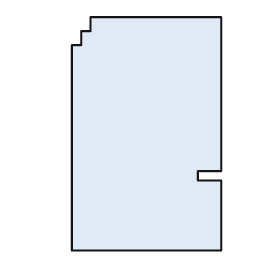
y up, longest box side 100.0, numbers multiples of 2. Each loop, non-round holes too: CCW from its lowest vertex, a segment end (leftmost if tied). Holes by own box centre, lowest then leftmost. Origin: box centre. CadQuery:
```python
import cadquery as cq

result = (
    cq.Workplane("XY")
    .moveTo(-32.0, -50.0)
    .lineTo(32.0, -50.0)
    .lineTo(32.0, -20.0)
    .lineTo(22.0, -20.0)
    .lineTo(22.0, -16.0)
    .lineTo(32.0, -16.0)
    .lineTo(32.0, 50.0)
    .lineTo(-24.0, 50.0)
    .lineTo(-24.0, 44.0)
    .lineTo(-28.0, 44.0)
    .lineTo(-28.0, 38.0)
    .lineTo(-32.0, 38.0)
    .close()
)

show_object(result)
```